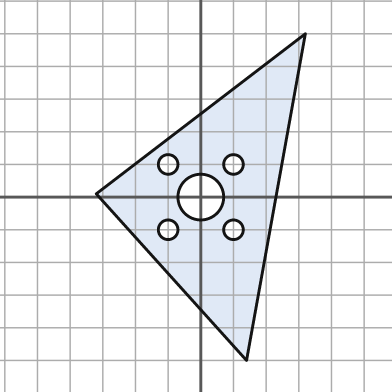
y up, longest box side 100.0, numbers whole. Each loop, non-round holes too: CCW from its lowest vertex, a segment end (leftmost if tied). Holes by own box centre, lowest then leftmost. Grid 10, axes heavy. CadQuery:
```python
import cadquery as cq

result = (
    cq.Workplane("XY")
    .moveTo(14.0, -50.0)
    .lineTo(32.0, 50.0)
    .lineTo(-32.0, 1.0)
    .close()
    .moveTo(-10.0, -10.0)
    .circle(3.0)
    .moveTo(10.0, -10.0)
    .circle(3.0)
    .moveTo(0.0, 0.0)
    .circle(7.0)
    .moveTo(-10.0, 10.0)
    .circle(3.0)
    .moveTo(10.0, 10.0)
    .circle(3.0)
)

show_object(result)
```